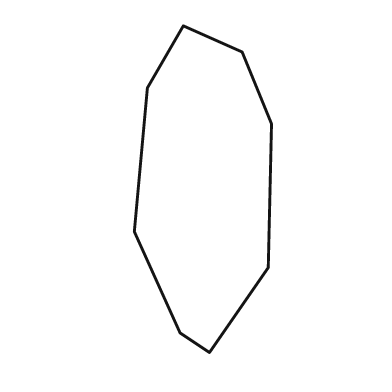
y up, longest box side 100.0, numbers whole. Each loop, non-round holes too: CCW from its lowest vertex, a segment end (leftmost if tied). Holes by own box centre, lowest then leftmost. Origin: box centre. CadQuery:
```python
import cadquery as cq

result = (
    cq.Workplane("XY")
    .moveTo(2.0, -50.0)
    .lineTo(20.0, -24.0)
    .lineTo(21.0, 20.0)
    .lineTo(12.0, 42.0)
    .lineTo(-6.0, 50.0)
    .lineTo(-17.0, 31.0)
    .lineTo(-21.0, -13.0)
    .lineTo(-7.0, -44.0)
    .close()
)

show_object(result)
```